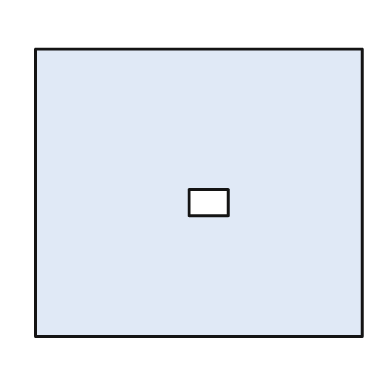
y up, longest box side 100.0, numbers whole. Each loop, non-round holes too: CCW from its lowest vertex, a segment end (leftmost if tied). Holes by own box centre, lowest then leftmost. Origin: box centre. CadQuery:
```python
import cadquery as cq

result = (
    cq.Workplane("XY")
    .moveTo(-50.0, -44.0)
    .lineTo(50.0, -44.0)
    .lineTo(50.0, 44.0)
    .lineTo(-50.0, 44.0)
    .close()
    .moveTo(-3.0, -7.0)
    .lineTo(9.0, -7.0)
    .lineTo(9.0, 1.0)
    .lineTo(-3.0, 1.0)
    .close()
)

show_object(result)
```